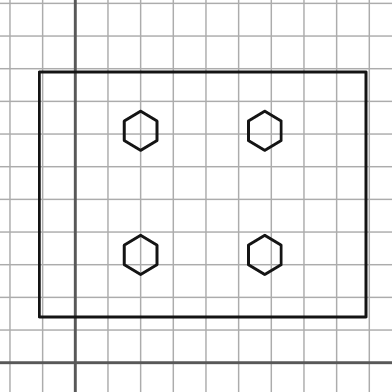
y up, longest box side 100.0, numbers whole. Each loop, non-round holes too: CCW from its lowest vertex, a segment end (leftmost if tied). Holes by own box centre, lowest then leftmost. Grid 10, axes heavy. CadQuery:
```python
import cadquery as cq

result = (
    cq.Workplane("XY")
    .moveTo(-11.0, 14.0)
    .lineTo(89.0, 14.0)
    .lineTo(89.0, 89.0)
    .lineTo(-11.0, 89.0)
    .close()
    .moveTo(20.0, 27.0)
    .lineTo(25.0, 30.0)
    .lineTo(25.0, 36.0)
    .lineTo(20.0, 39.0)
    .lineTo(15.0, 36.0)
    .lineTo(15.0, 30.0)
    .close()
    .moveTo(58.0, 27.0)
    .lineTo(63.0, 30.0)
    .lineTo(63.0, 36.0)
    .lineTo(58.0, 39.0)
    .lineTo(53.0, 36.0)
    .lineTo(53.0, 30.0)
    .close()
    .moveTo(20.0, 65.0)
    .lineTo(25.0, 68.0)
    .lineTo(25.0, 74.0)
    .lineTo(20.0, 77.0)
    .lineTo(15.0, 74.0)
    .lineTo(15.0, 68.0)
    .close()
    .moveTo(58.0, 65.0)
    .lineTo(63.0, 68.0)
    .lineTo(63.0, 74.0)
    .lineTo(58.0, 77.0)
    .lineTo(53.0, 74.0)
    .lineTo(53.0, 68.0)
    .close()
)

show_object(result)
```